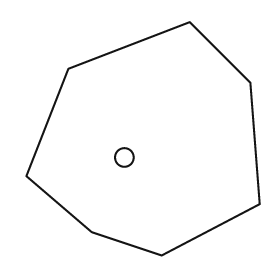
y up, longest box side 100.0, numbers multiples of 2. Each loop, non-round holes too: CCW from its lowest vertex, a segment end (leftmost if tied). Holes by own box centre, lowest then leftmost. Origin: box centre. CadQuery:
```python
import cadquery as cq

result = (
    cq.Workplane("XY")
    .moveTo(8.0, -50.0)
    .lineTo(50.0, -28.0)
    .lineTo(46.0, 24.0)
    .lineTo(20.0, 50.0)
    .lineTo(-32.0, 30.0)
    .lineTo(-50.0, -16.0)
    .lineTo(-22.0, -40.0)
    .close()
    .moveTo(-8.0, -8.0)
    .circle(4.0)
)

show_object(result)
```